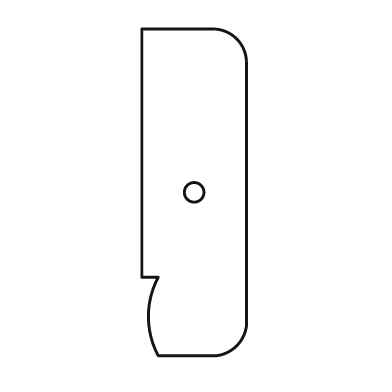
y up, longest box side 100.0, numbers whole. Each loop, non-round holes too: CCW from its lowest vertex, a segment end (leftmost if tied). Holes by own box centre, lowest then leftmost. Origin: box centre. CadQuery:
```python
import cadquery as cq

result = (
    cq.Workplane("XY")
    .moveTo(-11.0, -50.0)
    .lineTo(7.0, -50.0)
    .threePointArc((13.0, -47.0), (16.0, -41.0))
    .lineTo(16.0, 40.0)
    .threePointArc((13.0, 47.0), (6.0, 50.0))
    .lineTo(-16.0, 50.0)
    .lineTo(-16.0, -26.0)
    .lineTo(-11.0, -26.0)
    .threePointArc((-14.0, -38.0), (-11.0, -50.0))
    .close()
    .moveTo(0.0, 0.0)
    .circle(3.0)
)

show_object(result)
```